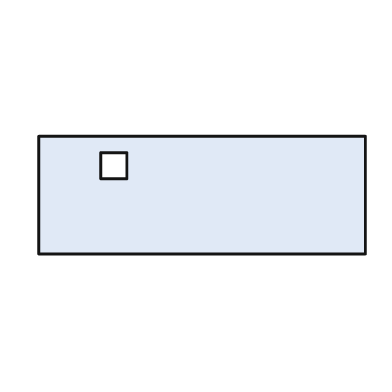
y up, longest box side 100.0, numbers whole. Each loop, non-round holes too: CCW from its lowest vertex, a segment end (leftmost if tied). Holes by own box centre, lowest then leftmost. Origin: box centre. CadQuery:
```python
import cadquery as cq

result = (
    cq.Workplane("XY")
    .moveTo(-50.0, -18.0)
    .lineTo(50.0, -18.0)
    .lineTo(50.0, 18.0)
    .lineTo(-50.0, 18.0)
    .close()
    .moveTo(-31.0, 5.0)
    .lineTo(-23.0, 5.0)
    .lineTo(-23.0, 13.0)
    .lineTo(-31.0, 13.0)
    .close()
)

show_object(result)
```